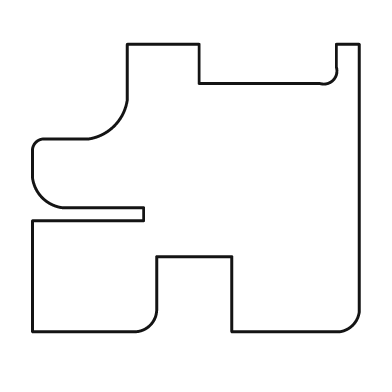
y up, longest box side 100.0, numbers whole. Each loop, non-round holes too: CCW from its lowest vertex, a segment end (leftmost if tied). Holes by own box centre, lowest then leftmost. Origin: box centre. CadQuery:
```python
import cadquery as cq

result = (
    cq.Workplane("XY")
    .moveTo(-50.0, -44.0)
    .lineTo(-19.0, -44.0)
    .threePointArc((-14.0, -42.0), (-12.0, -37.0))
    .lineTo(-12.0, -21.0)
    .lineTo(11.0, -21.0)
    .lineTo(11.0, -44.0)
    .lineTo(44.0, -44.0)
    .threePointArc((48.0, -42.0), (50.0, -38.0))
    .lineTo(50.0, 44.0)
    .lineTo(43.0, 44.0)
    .lineTo(43.0, 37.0)
    .threePointArc((42.0, 33.0), (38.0, 32.0))
    .lineTo(1.0, 32.0)
    .lineTo(1.0, 44.0)
    .lineTo(-21.0, 44.0)
    .lineTo(-21.0, 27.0)
    .threePointArc((-25.0, 19.0), (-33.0, 15.0))
    .lineTo(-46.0, 15.0)
    .threePointArc((-49.0, 14.0), (-50.0, 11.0))
    .lineTo(-50.0, 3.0)
    .threePointArc((-47.0, -3.0), (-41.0, -6.0))
    .lineTo(-16.0, -6.0)
    .lineTo(-16.0, -10.0)
    .lineTo(-50.0, -10.0)
    .close()
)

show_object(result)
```